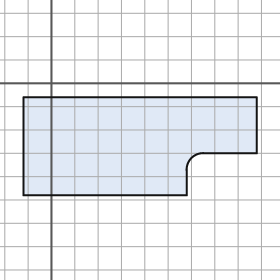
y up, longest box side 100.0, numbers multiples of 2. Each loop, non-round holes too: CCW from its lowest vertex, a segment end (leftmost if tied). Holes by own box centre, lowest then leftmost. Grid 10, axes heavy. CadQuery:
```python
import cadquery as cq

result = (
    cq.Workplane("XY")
    .moveTo(-12.0, -48.0)
    .lineTo(58.0, -48.0)
    .lineTo(58.0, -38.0)
    .threePointArc((60.0, -32.0), (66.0, -30.0))
    .lineTo(88.0, -30.0)
    .lineTo(88.0, -6.0)
    .lineTo(-12.0, -6.0)
    .close()
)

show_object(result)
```